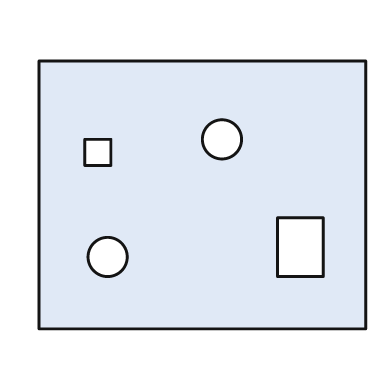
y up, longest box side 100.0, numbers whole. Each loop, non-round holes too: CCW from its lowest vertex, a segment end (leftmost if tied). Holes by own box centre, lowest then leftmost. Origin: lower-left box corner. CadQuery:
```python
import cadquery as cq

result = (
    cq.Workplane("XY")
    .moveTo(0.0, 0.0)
    .lineTo(100.0, 0.0)
    .lineTo(100.0, 82.0)
    .lineTo(0.0, 82.0)
    .close()
    .moveTo(21.0, 22.0)
    .circle(6.0)
    .moveTo(73.0, 16.0)
    .lineTo(87.0, 16.0)
    .lineTo(87.0, 34.0)
    .lineTo(73.0, 34.0)
    .close()
    .moveTo(14.0, 50.0)
    .lineTo(22.0, 50.0)
    .lineTo(22.0, 58.0)
    .lineTo(14.0, 58.0)
    .close()
    .moveTo(56.0, 58.0)
    .circle(6.0)
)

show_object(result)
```